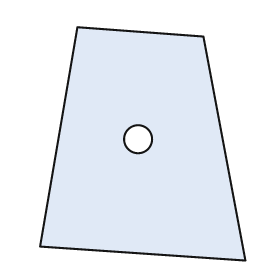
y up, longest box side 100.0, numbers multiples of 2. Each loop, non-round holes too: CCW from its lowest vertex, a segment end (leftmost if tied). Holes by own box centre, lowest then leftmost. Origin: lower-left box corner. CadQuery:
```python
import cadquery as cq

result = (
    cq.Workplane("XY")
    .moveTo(88.0, 0.0)
    .lineTo(70.0, 96.0)
    .lineTo(16.0, 100.0)
    .lineTo(0.0, 6.0)
    .close()
    .moveTo(42.0, 52.0)
    .circle(6.0)
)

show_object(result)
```